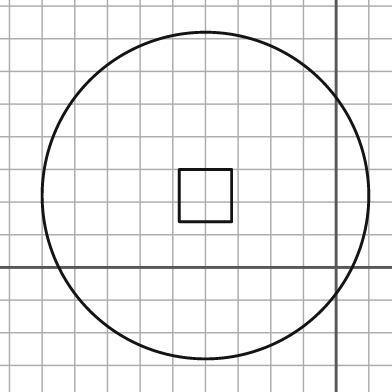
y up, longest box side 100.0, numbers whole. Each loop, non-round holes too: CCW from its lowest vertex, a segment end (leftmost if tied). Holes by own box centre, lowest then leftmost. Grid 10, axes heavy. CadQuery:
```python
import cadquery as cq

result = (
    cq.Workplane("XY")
    .moveTo(-40.0, 22.0)
    .circle(50.0)
    .moveTo(-48.0, 14.0)
    .lineTo(-32.0, 14.0)
    .lineTo(-32.0, 30.0)
    .lineTo(-48.0, 30.0)
    .close()
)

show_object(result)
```